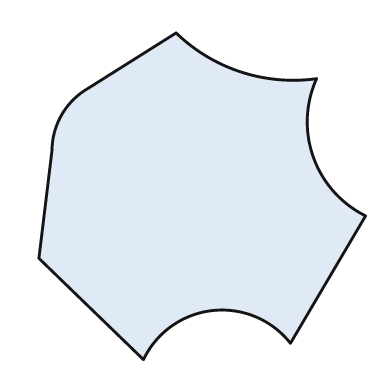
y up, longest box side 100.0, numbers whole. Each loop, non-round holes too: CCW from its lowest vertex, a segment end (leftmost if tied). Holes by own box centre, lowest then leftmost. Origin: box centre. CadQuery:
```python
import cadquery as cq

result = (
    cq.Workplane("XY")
    .moveTo(-18.0, -50.0)
    .threePointArc((3.0, -35.0), (27.0, -45.0))
    .lineTo(50.0, -6.0)
    .threePointArc((34.0, 12.0), (35.0, 36.0))
    .threePointArc((12.0, 38.0), (-8.0, 50.0))
    .lineTo(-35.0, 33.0)
    .threePointArc((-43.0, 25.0), (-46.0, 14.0))
    .lineTo(-50.0, -19.0)
    .close()
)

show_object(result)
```